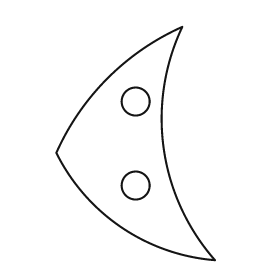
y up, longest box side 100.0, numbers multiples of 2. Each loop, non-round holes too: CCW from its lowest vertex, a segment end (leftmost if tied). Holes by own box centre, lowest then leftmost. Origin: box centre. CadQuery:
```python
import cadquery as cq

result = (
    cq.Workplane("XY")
    .moveTo(34.0, -50.0)
    .threePointArc((12.0, -2.0), (20.0, 50.0))
    .threePointArc((-12.0, 28.0), (-34.0, -4.0))
    .threePointArc((-6.0, -36.0), (34.0, -50.0))
    .close()
    .moveTo(0.0, -18.0)
    .circle(6.0)
    .moveTo(0.0, 18.0)
    .circle(6.0)
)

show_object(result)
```